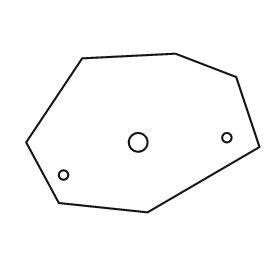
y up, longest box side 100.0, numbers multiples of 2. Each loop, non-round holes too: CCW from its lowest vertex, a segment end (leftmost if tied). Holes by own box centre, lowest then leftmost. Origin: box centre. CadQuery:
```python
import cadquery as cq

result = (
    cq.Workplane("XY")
    .moveTo(2.0, -34.0)
    .lineTo(50.0, -6.0)
    .lineTo(40.0, 24.0)
    .lineTo(14.0, 34.0)
    .lineTo(-26.0, 32.0)
    .lineTo(-50.0, -4.0)
    .lineTo(-36.0, -30.0)
    .close()
    .moveTo(-34.0, -18.0)
    .circle(2.0)
    .moveTo(-2.0, -4.0)
    .circle(4.0)
    .moveTo(36.0, -2.0)
    .circle(2.0)
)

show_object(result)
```